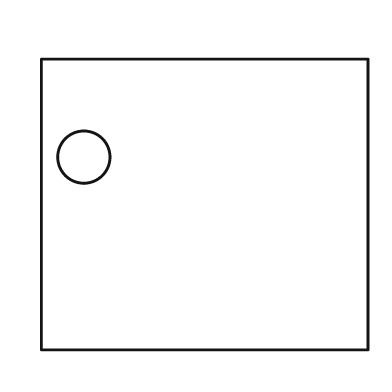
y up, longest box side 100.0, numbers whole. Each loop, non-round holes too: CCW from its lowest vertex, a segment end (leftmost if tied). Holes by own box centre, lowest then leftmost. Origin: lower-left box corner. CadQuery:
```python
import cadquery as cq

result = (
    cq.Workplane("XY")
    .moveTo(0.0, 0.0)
    .lineTo(100.0, 0.0)
    .lineTo(100.0, 89.0)
    .lineTo(0.0, 89.0)
    .close()
    .moveTo(13.0, 59.0)
    .circle(8.0)
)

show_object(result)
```